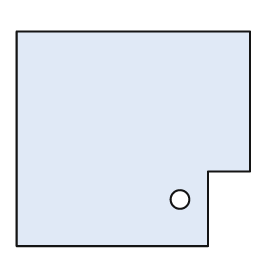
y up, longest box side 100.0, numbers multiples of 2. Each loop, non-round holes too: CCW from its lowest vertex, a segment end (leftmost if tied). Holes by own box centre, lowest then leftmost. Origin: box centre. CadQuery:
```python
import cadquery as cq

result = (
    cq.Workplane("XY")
    .moveTo(-50.0, -46.0)
    .lineTo(32.0, -46.0)
    .lineTo(32.0, -14.0)
    .lineTo(50.0, -14.0)
    .lineTo(50.0, 46.0)
    .lineTo(-50.0, 46.0)
    .close()
    .moveTo(20.0, -26.0)
    .circle(4.0)
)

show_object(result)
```